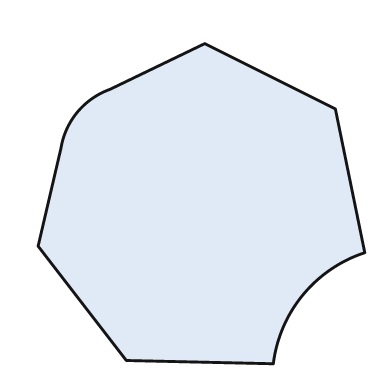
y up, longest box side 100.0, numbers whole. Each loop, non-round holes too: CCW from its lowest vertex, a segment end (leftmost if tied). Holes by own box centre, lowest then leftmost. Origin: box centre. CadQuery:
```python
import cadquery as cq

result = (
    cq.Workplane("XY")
    .moveTo(22.0, -49.0)
    .threePointArc((31.0, -28.0), (50.0, -15.0))
    .lineTo(41.0, 29.0)
    .lineTo(1.0, 49.0)
    .lineTo(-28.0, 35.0)
    .threePointArc((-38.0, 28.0), (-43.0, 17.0))
    .lineTo(-50.0, -13.0)
    .lineTo(-23.0, -48.0)
    .close()
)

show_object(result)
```